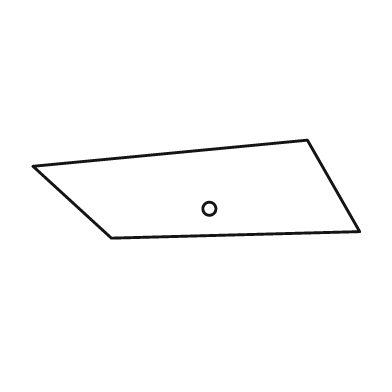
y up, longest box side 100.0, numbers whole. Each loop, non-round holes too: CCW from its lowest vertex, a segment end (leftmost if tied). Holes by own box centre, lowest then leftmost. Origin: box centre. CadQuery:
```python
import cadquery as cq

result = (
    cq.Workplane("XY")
    .moveTo(-26.0, -15.0)
    .lineTo(50.0, -13.0)
    .lineTo(34.0, 15.0)
    .lineTo(-50.0, 7.0)
    .close()
    .moveTo(4.0, -6.0)
    .circle(2.0)
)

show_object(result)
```